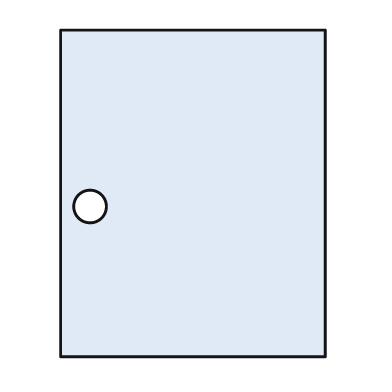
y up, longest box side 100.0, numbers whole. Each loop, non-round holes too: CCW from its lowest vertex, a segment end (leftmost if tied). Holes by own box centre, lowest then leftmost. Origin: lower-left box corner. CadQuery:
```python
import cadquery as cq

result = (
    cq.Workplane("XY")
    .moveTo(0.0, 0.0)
    .lineTo(81.0, 0.0)
    .lineTo(81.0, 100.0)
    .lineTo(0.0, 100.0)
    .close()
    .moveTo(9.0, 46.0)
    .circle(5.0)
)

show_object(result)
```